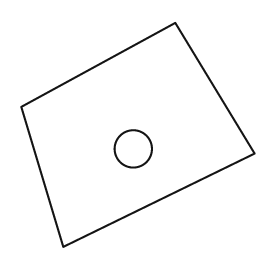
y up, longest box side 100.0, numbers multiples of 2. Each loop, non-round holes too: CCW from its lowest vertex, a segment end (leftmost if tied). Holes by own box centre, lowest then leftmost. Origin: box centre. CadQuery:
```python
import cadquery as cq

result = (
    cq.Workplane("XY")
    .moveTo(-32.0, -48.0)
    .lineTo(50.0, -8.0)
    .lineTo(16.0, 48.0)
    .lineTo(-50.0, 12.0)
    .close()
    .moveTo(-2.0, -6.0)
    .circle(8.0)
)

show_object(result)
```